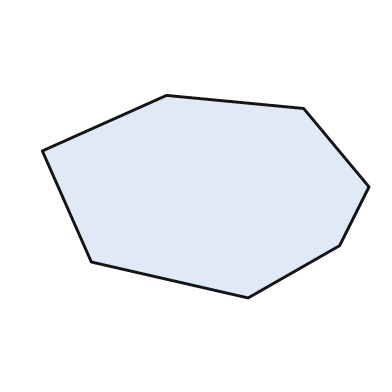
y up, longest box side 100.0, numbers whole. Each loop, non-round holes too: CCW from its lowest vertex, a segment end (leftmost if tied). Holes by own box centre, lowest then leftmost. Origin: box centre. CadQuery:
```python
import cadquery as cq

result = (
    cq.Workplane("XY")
    .moveTo(13.0, -31.0)
    .lineTo(41.0, -15.0)
    .lineTo(50.0, 3.0)
    .lineTo(30.0, 27.0)
    .lineTo(-12.0, 31.0)
    .lineTo(-50.0, 14.0)
    .lineTo(-35.0, -20.0)
    .close()
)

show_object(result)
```